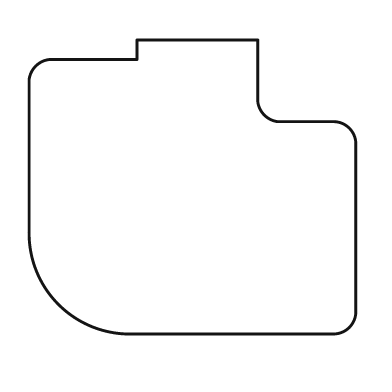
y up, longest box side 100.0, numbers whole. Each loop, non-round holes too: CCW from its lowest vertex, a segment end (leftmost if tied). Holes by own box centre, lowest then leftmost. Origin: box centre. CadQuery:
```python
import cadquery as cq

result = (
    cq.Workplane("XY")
    .moveTo(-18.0, -45.0)
    .lineTo(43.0, -45.0)
    .threePointArc((48.0, -43.0), (50.0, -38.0))
    .lineTo(50.0, 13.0)
    .threePointArc((48.0, 18.0), (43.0, 20.0))
    .lineTo(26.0, 20.0)
    .threePointArc((22.0, 22.0), (20.0, 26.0))
    .lineTo(20.0, 45.0)
    .lineTo(-17.0, 45.0)
    .lineTo(-17.0, 39.0)
    .lineTo(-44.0, 39.0)
    .threePointArc((-48.0, 37.0), (-50.0, 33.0))
    .lineTo(-50.0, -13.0)
    .threePointArc((-41.0, -36.0), (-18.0, -45.0))
    .close()
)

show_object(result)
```